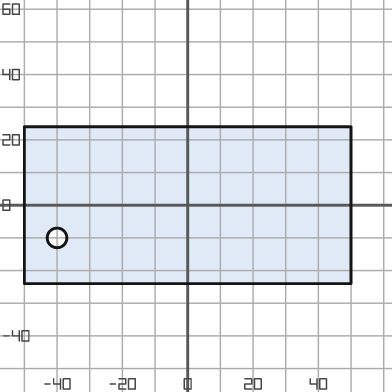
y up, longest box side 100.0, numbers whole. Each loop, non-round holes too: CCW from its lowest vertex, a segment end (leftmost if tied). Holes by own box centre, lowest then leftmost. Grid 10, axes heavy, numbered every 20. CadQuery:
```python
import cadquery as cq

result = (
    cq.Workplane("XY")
    .moveTo(-50.0, -24.0)
    .lineTo(50.0, -24.0)
    .lineTo(50.0, 24.0)
    .lineTo(-50.0, 24.0)
    .close()
    .moveTo(-40.0, -10.0)
    .circle(3.0)
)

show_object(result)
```